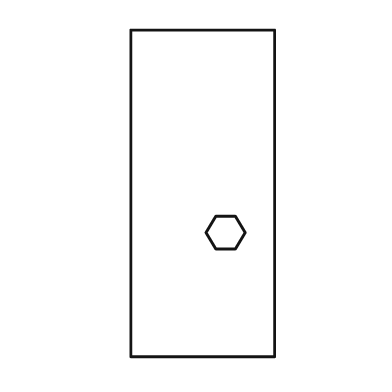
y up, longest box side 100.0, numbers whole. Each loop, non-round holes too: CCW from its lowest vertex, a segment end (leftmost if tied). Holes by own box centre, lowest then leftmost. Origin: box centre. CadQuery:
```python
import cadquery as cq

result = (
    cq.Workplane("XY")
    .moveTo(-22.0, -50.0)
    .lineTo(22.0, -50.0)
    .lineTo(22.0, 50.0)
    .lineTo(-22.0, 50.0)
    .close()
    .moveTo(4.0, -17.0)
    .lineTo(10.0, -17.0)
    .lineTo(13.0, -12.0)
    .lineTo(10.0, -7.0)
    .lineTo(4.0, -7.0)
    .lineTo(1.0, -12.0)
    .close()
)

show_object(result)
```